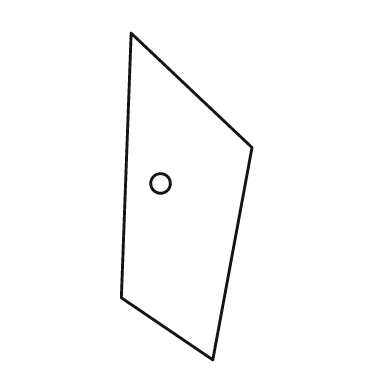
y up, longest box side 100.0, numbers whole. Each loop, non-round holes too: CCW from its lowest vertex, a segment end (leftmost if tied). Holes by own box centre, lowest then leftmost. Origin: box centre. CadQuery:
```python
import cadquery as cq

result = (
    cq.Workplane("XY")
    .moveTo(8.0, -50.0)
    .lineTo(20.0, 15.0)
    .lineTo(-17.0, 50.0)
    .lineTo(-20.0, -31.0)
    .close()
    .moveTo(-8.0, 4.0)
    .circle(3.0)
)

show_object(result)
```